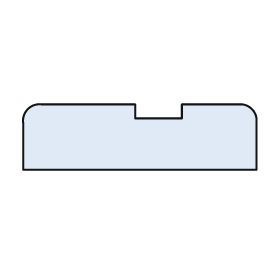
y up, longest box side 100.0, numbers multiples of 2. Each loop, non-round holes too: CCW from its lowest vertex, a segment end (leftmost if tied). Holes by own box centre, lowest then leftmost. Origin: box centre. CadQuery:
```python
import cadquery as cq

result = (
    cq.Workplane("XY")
    .moveTo(-50.0, -14.0)
    .lineTo(50.0, -14.0)
    .lineTo(50.0, 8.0)
    .threePointArc((48.0, 12.0), (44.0, 14.0))
    .lineTo(18.0, 14.0)
    .lineTo(18.0, 8.0)
    .lineTo(-2.0, 8.0)
    .lineTo(-2.0, 14.0)
    .lineTo(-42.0, 14.0)
    .threePointArc((-48.0, 12.0), (-50.0, 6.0))
    .close()
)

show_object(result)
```